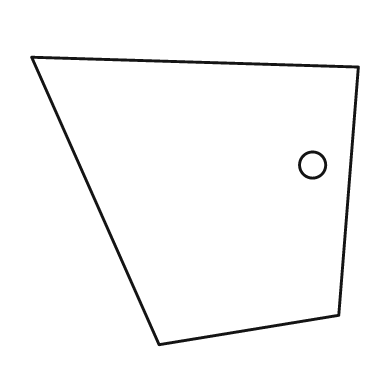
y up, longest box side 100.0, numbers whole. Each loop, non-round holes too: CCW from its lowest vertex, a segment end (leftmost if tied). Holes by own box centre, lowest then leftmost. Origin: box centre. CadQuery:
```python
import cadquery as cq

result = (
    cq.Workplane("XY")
    .moveTo(-11.0, -44.0)
    .lineTo(44.0, -35.0)
    .lineTo(50.0, 41.0)
    .lineTo(-50.0, 44.0)
    .close()
    .moveTo(36.0, 11.0)
    .circle(4.0)
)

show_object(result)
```